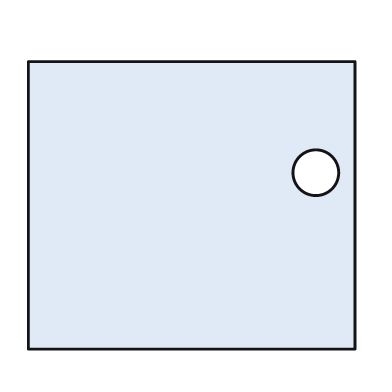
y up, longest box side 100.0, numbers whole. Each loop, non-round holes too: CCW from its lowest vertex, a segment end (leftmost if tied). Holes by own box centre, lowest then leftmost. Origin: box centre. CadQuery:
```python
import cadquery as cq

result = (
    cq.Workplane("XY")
    .moveTo(-50.0, -44.0)
    .lineTo(50.0, -44.0)
    .lineTo(50.0, 44.0)
    .lineTo(-50.0, 44.0)
    .close()
    .moveTo(38.0, 10.0)
    .circle(7.0)
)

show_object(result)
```